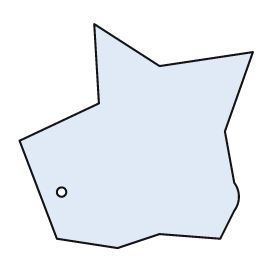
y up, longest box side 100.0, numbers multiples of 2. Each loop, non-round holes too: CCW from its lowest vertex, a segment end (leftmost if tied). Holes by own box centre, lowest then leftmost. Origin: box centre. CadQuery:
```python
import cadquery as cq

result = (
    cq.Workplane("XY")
    .moveTo(-8.0, -48.0)
    .lineTo(10.0, -42.0)
    .lineTo(36.0, -44.0)
    .lineTo(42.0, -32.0)
    .threePointArc((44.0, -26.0), (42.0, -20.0))
    .lineTo(38.0, 2.0)
    .lineTo(50.0, 36.0)
    .lineTo(10.0, 30.0)
    .lineTo(-18.0, 48.0)
    .lineTo(-16.0, 14.0)
    .lineTo(-50.0, -2.0)
    .lineTo(-34.0, -44.0)
    .close()
    .moveTo(-32.0, -24.0)
    .circle(2.0)
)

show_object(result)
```